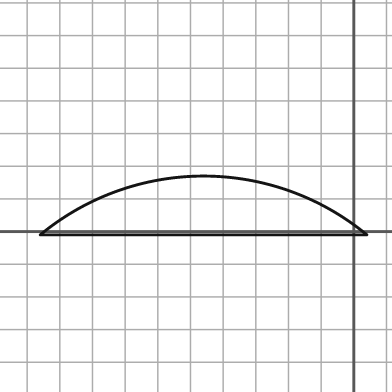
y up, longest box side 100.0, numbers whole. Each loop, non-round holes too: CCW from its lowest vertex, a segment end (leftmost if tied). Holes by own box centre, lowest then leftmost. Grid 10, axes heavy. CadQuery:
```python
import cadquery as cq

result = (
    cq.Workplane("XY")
    .moveTo(-96.0, -1.0)
    .lineTo(4.0, -1.0)
    .threePointArc((-46.0, 17.0), (-96.0, -1.0))
    .close()
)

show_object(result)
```